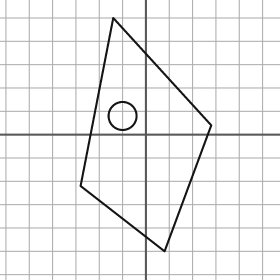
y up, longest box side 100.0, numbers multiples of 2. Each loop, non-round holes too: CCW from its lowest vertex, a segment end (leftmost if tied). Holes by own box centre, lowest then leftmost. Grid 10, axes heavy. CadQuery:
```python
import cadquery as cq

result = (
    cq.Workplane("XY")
    .moveTo(8.0, -50.0)
    .lineTo(28.0, 4.0)
    .lineTo(-14.0, 50.0)
    .lineTo(-28.0, -22.0)
    .close()
    .moveTo(-10.0, 8.0)
    .circle(6.0)
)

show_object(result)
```